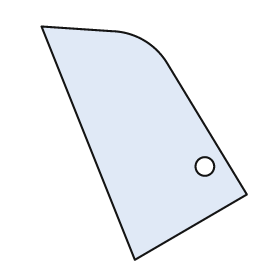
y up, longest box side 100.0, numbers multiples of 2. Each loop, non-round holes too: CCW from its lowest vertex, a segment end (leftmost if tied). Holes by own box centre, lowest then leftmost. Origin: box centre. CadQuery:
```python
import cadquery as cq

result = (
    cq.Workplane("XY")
    .moveTo(-4.0, -50.0)
    .lineTo(44.0, -22.0)
    .lineTo(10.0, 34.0)
    .threePointArc((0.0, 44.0), (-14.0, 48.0))
    .lineTo(-44.0, 50.0)
    .close()
    .moveTo(26.0, -10.0)
    .circle(4.0)
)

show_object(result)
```